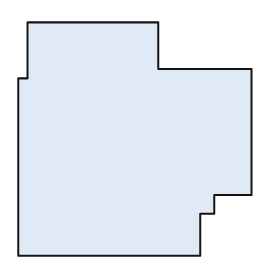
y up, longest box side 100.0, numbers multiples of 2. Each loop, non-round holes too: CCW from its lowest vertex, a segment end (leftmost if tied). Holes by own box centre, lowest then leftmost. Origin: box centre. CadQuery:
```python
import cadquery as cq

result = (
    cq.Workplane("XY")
    .moveTo(-50.0, -50.0)
    .lineTo(28.0, -50.0)
    .lineTo(28.0, -32.0)
    .lineTo(34.0, -32.0)
    .lineTo(34.0, -24.0)
    .lineTo(50.0, -24.0)
    .lineTo(50.0, 30.0)
    .lineTo(10.0, 30.0)
    .lineTo(10.0, 50.0)
    .lineTo(-46.0, 50.0)
    .lineTo(-46.0, 26.0)
    .lineTo(-50.0, 26.0)
    .close()
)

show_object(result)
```